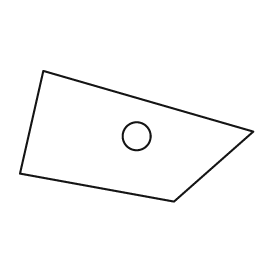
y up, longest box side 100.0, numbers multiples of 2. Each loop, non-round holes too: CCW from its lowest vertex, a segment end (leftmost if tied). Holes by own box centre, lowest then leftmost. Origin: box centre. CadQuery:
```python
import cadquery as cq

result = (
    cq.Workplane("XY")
    .moveTo(16.0, -28.0)
    .lineTo(50.0, 2.0)
    .lineTo(-40.0, 28.0)
    .lineTo(-50.0, -16.0)
    .close()
    .moveTo(0.0, 0.0)
    .circle(6.0)
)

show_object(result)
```